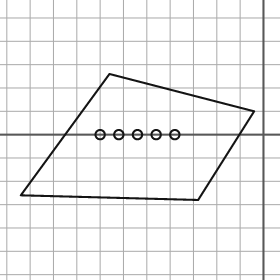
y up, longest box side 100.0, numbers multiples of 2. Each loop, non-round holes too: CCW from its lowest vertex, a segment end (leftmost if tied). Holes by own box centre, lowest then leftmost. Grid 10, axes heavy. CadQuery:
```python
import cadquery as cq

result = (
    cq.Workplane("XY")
    .moveTo(-28.0, -28.0)
    .lineTo(-4.0, 10.0)
    .lineTo(-66.0, 26.0)
    .lineTo(-104.0, -26.0)
    .close()
    .moveTo(-70.0, 0.0)
    .circle(2.0)
    .moveTo(-62.0, 0.0)
    .circle(2.0)
    .moveTo(-54.0, 0.0)
    .circle(2.0)
    .moveTo(-46.0, 0.0)
    .circle(2.0)
    .moveTo(-38.0, 0.0)
    .circle(2.0)
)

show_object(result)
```